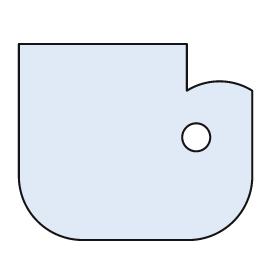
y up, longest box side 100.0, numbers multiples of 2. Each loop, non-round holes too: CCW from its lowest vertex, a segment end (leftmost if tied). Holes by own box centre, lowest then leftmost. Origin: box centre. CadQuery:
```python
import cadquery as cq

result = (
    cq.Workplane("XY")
    .moveTo(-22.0, -42.0)
    .lineTo(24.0, -42.0)
    .threePointArc((42.0, -34.0), (50.0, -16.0))
    .lineTo(50.0, 22.0)
    .threePointArc((36.0, 26.0), (22.0, 22.0))
    .lineTo(22.0, 42.0)
    .lineTo(-50.0, 42.0)
    .lineTo(-50.0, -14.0)
    .threePointArc((-42.0, -34.0), (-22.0, -42.0))
    .close()
    .moveTo(26.0, 2.0)
    .circle(6.0)
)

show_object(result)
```